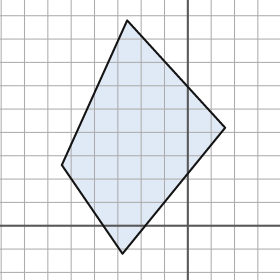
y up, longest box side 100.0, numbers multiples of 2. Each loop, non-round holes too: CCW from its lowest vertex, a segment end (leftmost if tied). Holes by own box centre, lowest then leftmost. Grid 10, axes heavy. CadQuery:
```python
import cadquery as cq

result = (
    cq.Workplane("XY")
    .moveTo(-28.0, -12.0)
    .lineTo(16.0, 42.0)
    .lineTo(-26.0, 88.0)
    .lineTo(-54.0, 26.0)
    .close()
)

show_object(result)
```